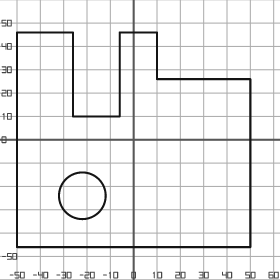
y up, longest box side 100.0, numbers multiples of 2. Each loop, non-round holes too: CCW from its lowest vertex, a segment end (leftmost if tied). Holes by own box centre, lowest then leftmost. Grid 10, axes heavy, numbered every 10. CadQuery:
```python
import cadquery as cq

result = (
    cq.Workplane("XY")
    .moveTo(-50.0, -46.0)
    .lineTo(50.0, -46.0)
    .lineTo(50.0, 26.0)
    .lineTo(10.0, 26.0)
    .lineTo(10.0, 46.0)
    .lineTo(-6.0, 46.0)
    .lineTo(-6.0, 10.0)
    .lineTo(-26.0, 10.0)
    .lineTo(-26.0, 46.0)
    .lineTo(-50.0, 46.0)
    .close()
    .moveTo(-22.0, -24.0)
    .circle(10.0)
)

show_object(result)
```